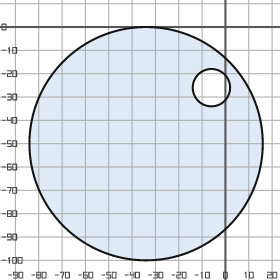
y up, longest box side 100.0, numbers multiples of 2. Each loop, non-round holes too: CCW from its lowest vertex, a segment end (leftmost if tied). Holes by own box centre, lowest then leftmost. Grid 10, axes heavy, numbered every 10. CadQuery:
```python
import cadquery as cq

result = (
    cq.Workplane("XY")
    .moveTo(-34.0, -50.0)
    .circle(50.0)
    .moveTo(-6.0, -26.0)
    .circle(8.0)
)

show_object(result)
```